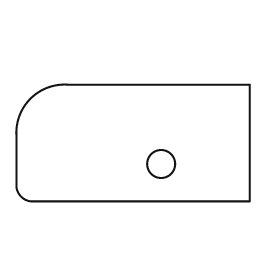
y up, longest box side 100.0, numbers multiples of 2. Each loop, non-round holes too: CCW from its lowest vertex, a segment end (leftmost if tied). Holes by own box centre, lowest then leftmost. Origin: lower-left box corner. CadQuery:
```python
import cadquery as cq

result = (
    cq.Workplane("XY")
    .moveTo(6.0, 0.0)
    .lineTo(100.0, 0.0)
    .lineTo(100.0, 50.0)
    .lineTo(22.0, 50.0)
    .threePointArc((6.0, 44.0), (0.0, 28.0))
    .lineTo(0.0, 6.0)
    .threePointArc((2.0, 2.0), (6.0, 0.0))
    .close()
    .moveTo(62.0, 16.0)
    .circle(6.0)
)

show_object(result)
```